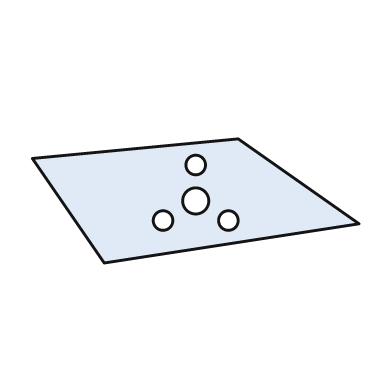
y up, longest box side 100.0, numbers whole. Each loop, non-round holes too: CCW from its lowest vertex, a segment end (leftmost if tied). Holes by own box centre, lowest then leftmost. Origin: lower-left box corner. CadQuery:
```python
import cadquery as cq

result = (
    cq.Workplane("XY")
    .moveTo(22.0, 0.0)
    .lineTo(100.0, 12.0)
    .lineTo(63.0, 38.0)
    .lineTo(0.0, 32.0)
    .close()
    .moveTo(40.0, 13.0)
    .circle(3.0)
    .moveTo(60.0, 13.0)
    .circle(3.0)
    .moveTo(50.0, 19.0)
    .circle(4.0)
    .moveTo(50.0, 30.0)
    .circle(3.0)
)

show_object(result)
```